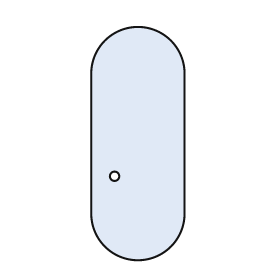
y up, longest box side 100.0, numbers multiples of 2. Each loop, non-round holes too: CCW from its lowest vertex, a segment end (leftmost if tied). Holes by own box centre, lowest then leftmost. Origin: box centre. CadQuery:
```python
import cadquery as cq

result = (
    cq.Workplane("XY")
    .moveTo(-20.0, -30.0)
    .threePointArc((0.0, -50.0), (20.0, -30.0))
    .lineTo(20.0, 30.0)
    .threePointArc((0.0, 50.0), (-20.0, 30.0))
    .close()
    .moveTo(-10.0, -14.0)
    .circle(2.0)
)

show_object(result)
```